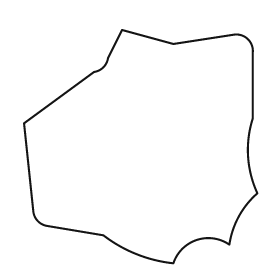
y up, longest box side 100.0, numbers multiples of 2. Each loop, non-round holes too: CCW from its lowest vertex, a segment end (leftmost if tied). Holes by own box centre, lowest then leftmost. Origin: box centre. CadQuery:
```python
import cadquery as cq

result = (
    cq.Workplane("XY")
    .moveTo(14.0, -50.0)
    .threePointArc((24.0, -40.0), (38.0, -42.0))
    .threePointArc((42.0, -30.0), (50.0, -20.0))
    .threePointArc((46.0, -4.0), (48.0, 12.0))
    .lineTo(48.0, 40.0)
    .threePointArc((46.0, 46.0), (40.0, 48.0))
    .lineTo(14.0, 44.0)
    .lineTo(-8.0, 50.0)
    .lineTo(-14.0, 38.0)
    .threePointArc((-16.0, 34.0), (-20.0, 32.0))
    .lineTo(-50.0, 10.0)
    .lineTo(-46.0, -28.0)
    .threePointArc((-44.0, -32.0), (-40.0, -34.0))
    .lineTo(-16.0, -38.0)
    .threePointArc((-2.0, -46.0), (14.0, -50.0))
    .close()
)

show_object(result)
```